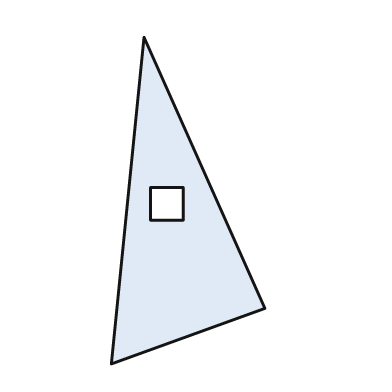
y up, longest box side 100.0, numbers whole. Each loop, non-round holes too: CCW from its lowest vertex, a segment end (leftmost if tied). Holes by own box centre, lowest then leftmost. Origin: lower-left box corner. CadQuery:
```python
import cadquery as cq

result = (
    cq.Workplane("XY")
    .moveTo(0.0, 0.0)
    .lineTo(47.0, 17.0)
    .lineTo(10.0, 100.0)
    .close()
    .moveTo(12.0, 44.0)
    .lineTo(22.0, 44.0)
    .lineTo(22.0, 54.0)
    .lineTo(12.0, 54.0)
    .close()
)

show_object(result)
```